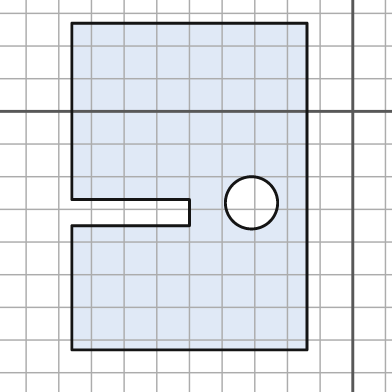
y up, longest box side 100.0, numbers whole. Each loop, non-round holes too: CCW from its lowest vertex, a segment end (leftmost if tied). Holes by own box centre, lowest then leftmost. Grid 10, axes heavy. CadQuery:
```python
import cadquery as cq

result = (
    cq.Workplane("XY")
    .moveTo(-86.0, -73.0)
    .lineTo(-14.0, -73.0)
    .lineTo(-14.0, 27.0)
    .lineTo(-86.0, 27.0)
    .lineTo(-86.0, -27.0)
    .lineTo(-50.0, -27.0)
    .lineTo(-50.0, -35.0)
    .lineTo(-86.0, -35.0)
    .close()
    .moveTo(-31.0, -28.0)
    .circle(8.0)
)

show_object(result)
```